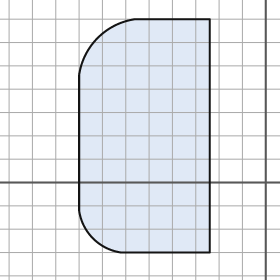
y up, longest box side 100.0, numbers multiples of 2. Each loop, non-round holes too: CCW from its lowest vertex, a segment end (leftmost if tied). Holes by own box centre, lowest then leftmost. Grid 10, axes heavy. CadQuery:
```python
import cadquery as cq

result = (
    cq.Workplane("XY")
    .moveTo(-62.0, -30.0)
    .lineTo(-24.0, -30.0)
    .lineTo(-24.0, 70.0)
    .lineTo(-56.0, 70.0)
    .threePointArc((-72.0, 62.0), (-80.0, 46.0))
    .lineTo(-80.0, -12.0)
    .threePointArc((-74.0, -24.0), (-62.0, -30.0))
    .close()
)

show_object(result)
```